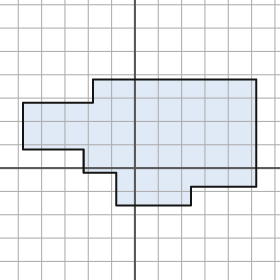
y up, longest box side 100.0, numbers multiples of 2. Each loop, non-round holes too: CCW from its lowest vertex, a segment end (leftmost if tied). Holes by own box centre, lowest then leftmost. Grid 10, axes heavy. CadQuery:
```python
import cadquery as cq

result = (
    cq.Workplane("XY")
    .moveTo(-8.0, -16.0)
    .lineTo(24.0, -16.0)
    .lineTo(24.0, -8.0)
    .lineTo(52.0, -8.0)
    .lineTo(52.0, 38.0)
    .lineTo(-18.0, 38.0)
    .lineTo(-18.0, 28.0)
    .lineTo(-48.0, 28.0)
    .lineTo(-48.0, 8.0)
    .lineTo(-22.0, 8.0)
    .lineTo(-22.0, -2.0)
    .lineTo(-8.0, -2.0)
    .close()
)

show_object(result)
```